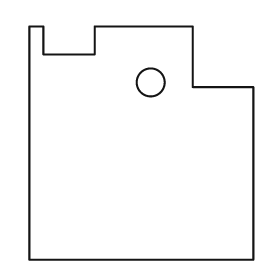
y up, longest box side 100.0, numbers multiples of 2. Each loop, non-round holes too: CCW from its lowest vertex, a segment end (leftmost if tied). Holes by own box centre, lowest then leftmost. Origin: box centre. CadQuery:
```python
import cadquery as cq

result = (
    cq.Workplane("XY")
    .moveTo(-48.0, -50.0)
    .lineTo(48.0, -50.0)
    .lineTo(48.0, 24.0)
    .lineTo(22.0, 24.0)
    .lineTo(22.0, 50.0)
    .lineTo(-20.0, 50.0)
    .lineTo(-20.0, 38.0)
    .lineTo(-42.0, 38.0)
    .lineTo(-42.0, 50.0)
    .lineTo(-48.0, 50.0)
    .close()
    .moveTo(4.0, 26.0)
    .circle(6.0)
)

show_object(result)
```